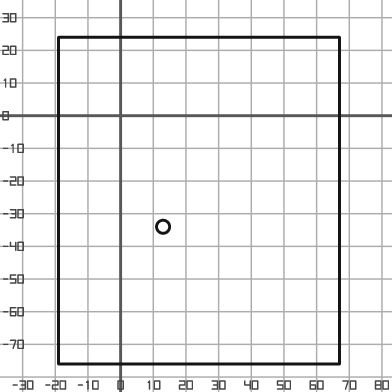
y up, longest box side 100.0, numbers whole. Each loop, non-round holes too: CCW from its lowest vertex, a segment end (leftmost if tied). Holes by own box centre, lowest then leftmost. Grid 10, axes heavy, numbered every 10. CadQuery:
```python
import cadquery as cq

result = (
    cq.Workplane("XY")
    .moveTo(-19.0, -76.0)
    .lineTo(67.0, -76.0)
    .lineTo(67.0, 24.0)
    .lineTo(-19.0, 24.0)
    .close()
    .moveTo(13.0, -34.0)
    .circle(2.0)
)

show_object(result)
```